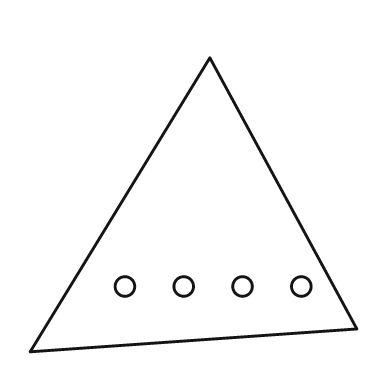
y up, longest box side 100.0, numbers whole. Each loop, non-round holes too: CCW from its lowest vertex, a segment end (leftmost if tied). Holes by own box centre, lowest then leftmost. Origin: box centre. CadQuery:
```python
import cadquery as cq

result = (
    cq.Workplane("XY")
    .moveTo(-50.0, -45.0)
    .lineTo(50.0, -38.0)
    .lineTo(5.0, 45.0)
    .close()
    .moveTo(-21.0, -25.0)
    .circle(3.0)
    .moveTo(-3.0, -25.0)
    .circle(3.0)
    .moveTo(15.0, -25.0)
    .circle(3.0)
    .moveTo(33.0, -25.0)
    .circle(3.0)
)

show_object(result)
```